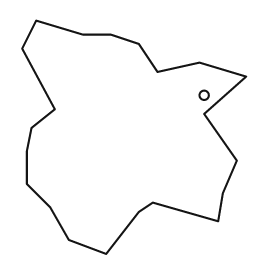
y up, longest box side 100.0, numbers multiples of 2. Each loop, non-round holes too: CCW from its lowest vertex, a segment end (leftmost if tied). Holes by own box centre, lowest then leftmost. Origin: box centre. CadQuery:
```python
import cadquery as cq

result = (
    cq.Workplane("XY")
    .moveTo(-12.0, -50.0)
    .lineTo(2.0, -32.0)
    .lineTo(8.0, -28.0)
    .lineTo(36.0, -36.0)
    .lineTo(38.0, -24.0)
    .lineTo(44.0, -10.0)
    .lineTo(30.0, 10.0)
    .lineTo(48.0, 26.0)
    .lineTo(28.0, 32.0)
    .lineTo(10.0, 28.0)
    .lineTo(2.0, 40.0)
    .lineTo(-10.0, 44.0)
    .lineTo(-22.0, 44.0)
    .lineTo(-42.0, 50.0)
    .lineTo(-48.0, 38.0)
    .lineTo(-34.0, 12.0)
    .lineTo(-44.0, 4.0)
    .lineTo(-46.0, -6.0)
    .lineTo(-46.0, -20.0)
    .lineTo(-36.0, -30.0)
    .lineTo(-28.0, -44.0)
    .close()
    .moveTo(30.0, 18.0)
    .circle(2.0)
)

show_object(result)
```